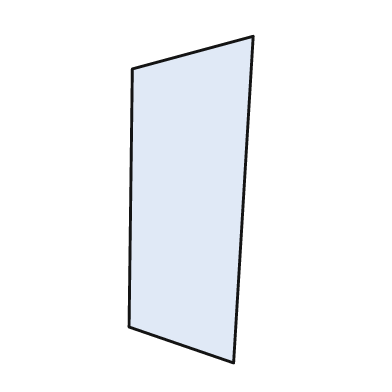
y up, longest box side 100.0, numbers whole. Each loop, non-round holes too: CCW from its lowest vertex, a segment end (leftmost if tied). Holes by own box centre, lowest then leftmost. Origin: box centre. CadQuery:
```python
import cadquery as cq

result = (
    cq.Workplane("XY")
    .moveTo(13.0, -50.0)
    .lineTo(19.0, 50.0)
    .lineTo(-18.0, 40.0)
    .lineTo(-19.0, -39.0)
    .close()
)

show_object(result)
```